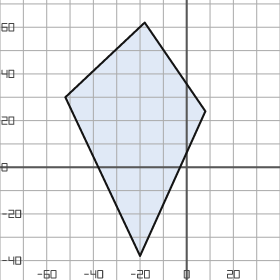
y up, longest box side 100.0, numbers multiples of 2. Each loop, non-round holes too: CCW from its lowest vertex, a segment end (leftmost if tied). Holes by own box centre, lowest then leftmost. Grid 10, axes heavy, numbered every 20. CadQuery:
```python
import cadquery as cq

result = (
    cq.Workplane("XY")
    .moveTo(-20.0, -38.0)
    .lineTo(8.0, 24.0)
    .lineTo(-18.0, 62.0)
    .lineTo(-52.0, 30.0)
    .close()
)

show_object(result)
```